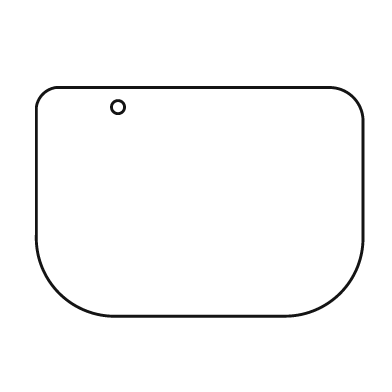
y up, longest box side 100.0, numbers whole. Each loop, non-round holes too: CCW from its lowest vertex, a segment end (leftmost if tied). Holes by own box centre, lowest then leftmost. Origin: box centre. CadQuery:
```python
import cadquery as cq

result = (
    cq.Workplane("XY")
    .moveTo(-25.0, -35.0)
    .lineTo(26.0, -35.0)
    .threePointArc((43.0, -28.0), (50.0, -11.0))
    .lineTo(50.0, 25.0)
    .threePointArc((47.0, 32.0), (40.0, 35.0))
    .lineTo(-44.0, 35.0)
    .threePointArc((-48.0, 33.0), (-50.0, 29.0))
    .lineTo(-50.0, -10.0)
    .threePointArc((-43.0, -28.0), (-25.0, -35.0))
    .close()
    .moveTo(-25.0, 29.0)
    .circle(2.0)
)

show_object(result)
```